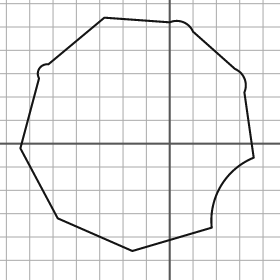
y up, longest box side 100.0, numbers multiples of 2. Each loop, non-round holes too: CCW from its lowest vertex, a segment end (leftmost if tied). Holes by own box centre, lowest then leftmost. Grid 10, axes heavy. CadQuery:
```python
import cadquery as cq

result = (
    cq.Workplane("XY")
    .moveTo(-16.0, -46.0)
    .lineTo(18.0, -36.0)
    .threePointArc((22.0, -18.0), (36.0, -6.0))
    .lineTo(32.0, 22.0)
    .threePointArc((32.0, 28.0), (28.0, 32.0))
    .lineTo(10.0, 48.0)
    .threePointArc((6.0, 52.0), (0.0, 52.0))
    .lineTo(-28.0, 54.0)
    .lineTo(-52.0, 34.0)
    .threePointArc((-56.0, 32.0), (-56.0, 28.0))
    .lineTo(-64.0, -2.0)
    .lineTo(-48.0, -32.0)
    .close()
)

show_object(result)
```